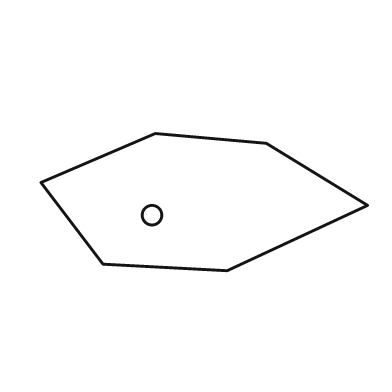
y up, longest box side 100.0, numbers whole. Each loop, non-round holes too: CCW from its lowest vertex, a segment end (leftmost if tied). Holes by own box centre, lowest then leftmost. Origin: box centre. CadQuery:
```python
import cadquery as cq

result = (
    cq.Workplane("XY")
    .moveTo(7.0, -21.0)
    .lineTo(50.0, -1.0)
    .lineTo(19.0, 18.0)
    .lineTo(-15.0, 21.0)
    .lineTo(-50.0, 6.0)
    .lineTo(-31.0, -19.0)
    .close()
    .moveTo(-16.0, -4.0)
    .circle(3.0)
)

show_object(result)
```